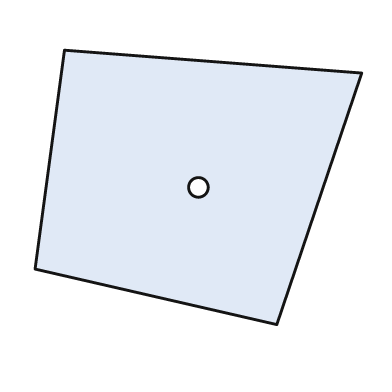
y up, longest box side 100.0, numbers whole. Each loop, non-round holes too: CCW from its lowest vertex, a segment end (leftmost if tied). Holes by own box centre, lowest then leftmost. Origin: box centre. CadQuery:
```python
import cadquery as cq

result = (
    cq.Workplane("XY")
    .moveTo(24.0, -42.0)
    .lineTo(50.0, 35.0)
    .lineTo(-41.0, 42.0)
    .lineTo(-50.0, -25.0)
    .close()
    .moveTo(0.0, 0.0)
    .circle(3.0)
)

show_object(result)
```